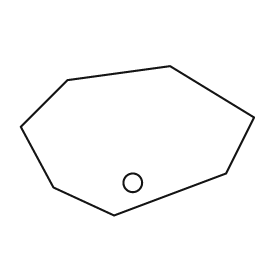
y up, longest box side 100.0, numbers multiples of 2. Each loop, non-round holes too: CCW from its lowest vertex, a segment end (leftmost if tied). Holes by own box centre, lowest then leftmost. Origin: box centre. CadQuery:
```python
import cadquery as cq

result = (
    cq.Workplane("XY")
    .moveTo(-10.0, -32.0)
    .lineTo(38.0, -14.0)
    .lineTo(50.0, 10.0)
    .lineTo(14.0, 32.0)
    .lineTo(-30.0, 26.0)
    .lineTo(-50.0, 6.0)
    .lineTo(-36.0, -20.0)
    .close()
    .moveTo(-2.0, -18.0)
    .circle(4.0)
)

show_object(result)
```